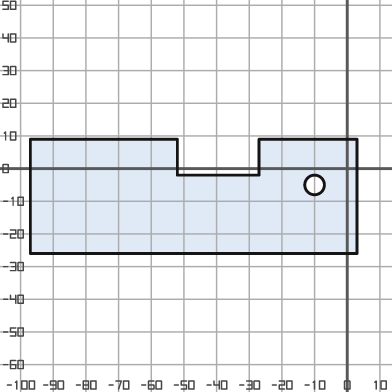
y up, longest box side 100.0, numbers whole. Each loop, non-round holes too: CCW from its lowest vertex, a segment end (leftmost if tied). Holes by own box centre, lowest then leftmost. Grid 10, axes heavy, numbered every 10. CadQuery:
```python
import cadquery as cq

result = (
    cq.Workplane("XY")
    .moveTo(-97.0, -26.0)
    .lineTo(3.0, -26.0)
    .lineTo(3.0, 9.0)
    .lineTo(-27.0, 9.0)
    .lineTo(-27.0, -2.0)
    .lineTo(-52.0, -2.0)
    .lineTo(-52.0, 9.0)
    .lineTo(-97.0, 9.0)
    .close()
    .moveTo(-10.0, -5.0)
    .circle(3.0)
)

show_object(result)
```